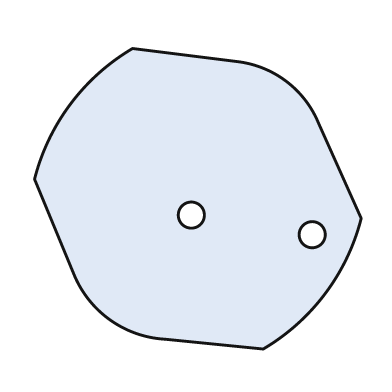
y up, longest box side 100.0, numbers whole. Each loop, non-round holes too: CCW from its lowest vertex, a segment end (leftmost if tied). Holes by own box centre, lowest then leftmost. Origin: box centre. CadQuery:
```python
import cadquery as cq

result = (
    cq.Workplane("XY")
    .moveTo(20.0, -46.0)
    .threePointArc((39.0, -29.0), (50.0, -6.0))
    .lineTo(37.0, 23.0)
    .threePointArc((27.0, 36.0), (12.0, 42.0))
    .lineTo(-20.0, 46.0)
    .threePointArc((-39.0, 29.0), (-50.0, 6.0))
    .lineTo(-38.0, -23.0)
    .threePointArc((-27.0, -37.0), (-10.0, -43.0))
    .close()
    .moveTo(35.0, -11.0)
    .circle(4.0)
    .moveTo(-2.0, -5.0)
    .circle(4.0)
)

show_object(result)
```